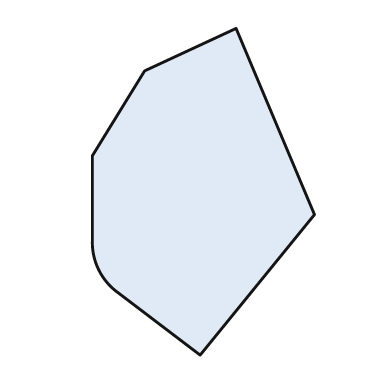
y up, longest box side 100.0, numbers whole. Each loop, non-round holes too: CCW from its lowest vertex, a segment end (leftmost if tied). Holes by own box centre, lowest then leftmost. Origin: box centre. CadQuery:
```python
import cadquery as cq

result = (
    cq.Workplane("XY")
    .moveTo(-1.0, -50.0)
    .lineTo(34.0, -7.0)
    .lineTo(10.0, 50.0)
    .lineTo(-18.0, 37.0)
    .lineTo(-34.0, 11.0)
    .lineTo(-34.0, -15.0)
    .threePointArc((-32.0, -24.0), (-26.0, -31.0))
    .close()
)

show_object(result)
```